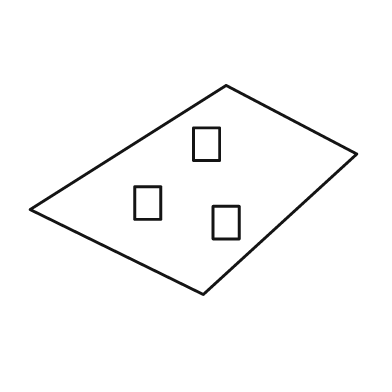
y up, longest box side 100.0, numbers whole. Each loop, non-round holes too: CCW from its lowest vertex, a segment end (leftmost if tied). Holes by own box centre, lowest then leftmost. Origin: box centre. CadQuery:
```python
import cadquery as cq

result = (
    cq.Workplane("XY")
    .moveTo(3.0, -32.0)
    .lineTo(50.0, 11.0)
    .lineTo(10.0, 32.0)
    .lineTo(-50.0, -6.0)
    .close()
    .moveTo(6.0, -15.0)
    .lineTo(14.0, -15.0)
    .lineTo(14.0, -5.0)
    .lineTo(6.0, -5.0)
    .close()
    .moveTo(-18.0, -9.0)
    .lineTo(-10.0, -9.0)
    .lineTo(-10.0, 1.0)
    .lineTo(-18.0, 1.0)
    .close()
    .moveTo(0.0, 9.0)
    .lineTo(8.0, 9.0)
    .lineTo(8.0, 19.0)
    .lineTo(0.0, 19.0)
    .close()
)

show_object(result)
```